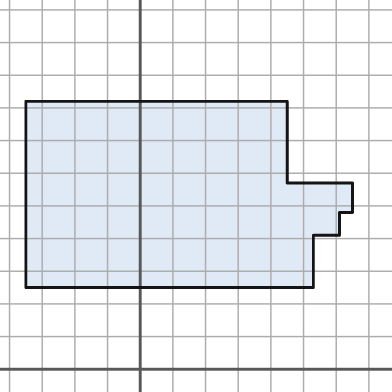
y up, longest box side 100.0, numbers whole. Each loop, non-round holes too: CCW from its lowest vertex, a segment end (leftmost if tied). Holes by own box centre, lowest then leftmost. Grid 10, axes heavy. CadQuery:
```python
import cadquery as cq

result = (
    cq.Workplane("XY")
    .moveTo(-35.0, 25.0)
    .lineTo(53.0, 25.0)
    .lineTo(53.0, 41.0)
    .lineTo(61.0, 41.0)
    .lineTo(61.0, 48.0)
    .lineTo(65.0, 48.0)
    .lineTo(65.0, 57.0)
    .lineTo(45.0, 57.0)
    .lineTo(45.0, 82.0)
    .lineTo(-35.0, 82.0)
    .close()
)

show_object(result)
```